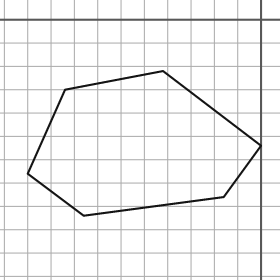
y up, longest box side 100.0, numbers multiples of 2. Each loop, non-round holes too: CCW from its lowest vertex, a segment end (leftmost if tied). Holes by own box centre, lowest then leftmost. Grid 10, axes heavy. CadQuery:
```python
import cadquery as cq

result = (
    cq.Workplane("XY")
    .moveTo(-76.0, -84.0)
    .lineTo(-16.0, -76.0)
    .lineTo(0.0, -54.0)
    .lineTo(-42.0, -22.0)
    .lineTo(-84.0, -30.0)
    .lineTo(-100.0, -66.0)
    .close()
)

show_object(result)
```